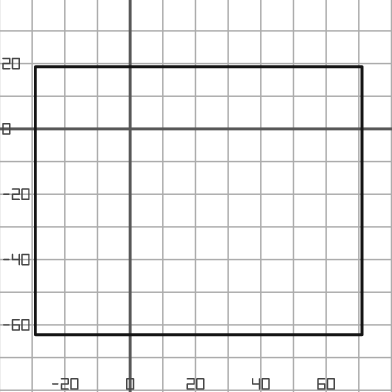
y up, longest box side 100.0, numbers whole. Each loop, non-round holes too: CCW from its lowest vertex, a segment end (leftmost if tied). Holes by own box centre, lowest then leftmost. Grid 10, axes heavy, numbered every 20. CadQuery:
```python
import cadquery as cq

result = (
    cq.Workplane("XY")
    .moveTo(-29.0, -63.0)
    .lineTo(71.0, -63.0)
    .lineTo(71.0, 19.0)
    .lineTo(-29.0, 19.0)
    .close()
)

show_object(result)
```